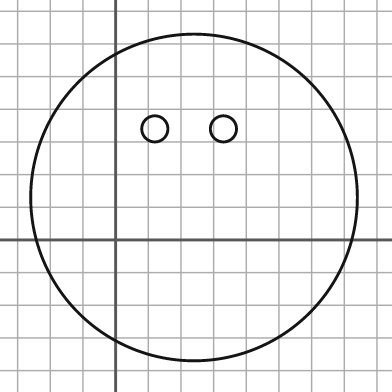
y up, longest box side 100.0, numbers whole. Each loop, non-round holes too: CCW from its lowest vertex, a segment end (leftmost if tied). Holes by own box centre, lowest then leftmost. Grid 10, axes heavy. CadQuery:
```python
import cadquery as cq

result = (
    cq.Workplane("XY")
    .moveTo(24.0, 13.0)
    .circle(50.0)
    .moveTo(12.0, 34.0)
    .circle(4.0)
    .moveTo(33.0, 34.0)
    .circle(4.0)
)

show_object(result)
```